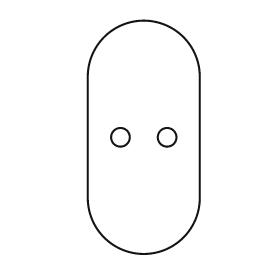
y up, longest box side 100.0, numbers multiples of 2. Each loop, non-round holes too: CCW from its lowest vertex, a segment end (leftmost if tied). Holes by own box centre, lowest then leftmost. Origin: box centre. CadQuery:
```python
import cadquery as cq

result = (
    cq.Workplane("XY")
    .moveTo(-24.0, -26.0)
    .threePointArc((0.0, -50.0), (24.0, -26.0))
    .lineTo(24.0, 26.0)
    .threePointArc((0.0, 50.0), (-24.0, 26.0))
    .close()
    .moveTo(-10.0, 0.0)
    .circle(4.0)
    .moveTo(10.0, 0.0)
    .circle(4.0)
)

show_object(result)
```